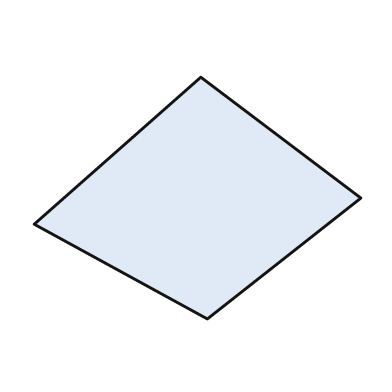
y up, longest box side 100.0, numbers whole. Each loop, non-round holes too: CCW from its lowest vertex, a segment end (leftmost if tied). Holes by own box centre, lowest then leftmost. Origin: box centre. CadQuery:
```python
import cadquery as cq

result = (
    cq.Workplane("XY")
    .moveTo(3.0, -37.0)
    .lineTo(50.0, 0.0)
    .lineTo(1.0, 37.0)
    .lineTo(-50.0, -8.0)
    .close()
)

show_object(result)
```